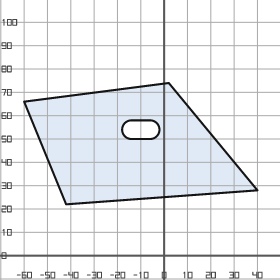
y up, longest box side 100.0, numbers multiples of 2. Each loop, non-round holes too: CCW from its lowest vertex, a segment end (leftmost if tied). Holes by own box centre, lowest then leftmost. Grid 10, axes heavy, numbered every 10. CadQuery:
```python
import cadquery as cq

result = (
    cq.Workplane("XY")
    .moveTo(-42.0, 22.0)
    .lineTo(40.0, 28.0)
    .lineTo(2.0, 74.0)
    .lineTo(-60.0, 66.0)
    .close()
    .moveTo(-14.0, 50.0)
    .lineTo(-6.0, 50.0)
    .threePointArc((-2.0, 54.0), (-6.0, 58.0))
    .lineTo(-14.0, 58.0)
    .threePointArc((-18.0, 54.0), (-14.0, 50.0))
    .close()
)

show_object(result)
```